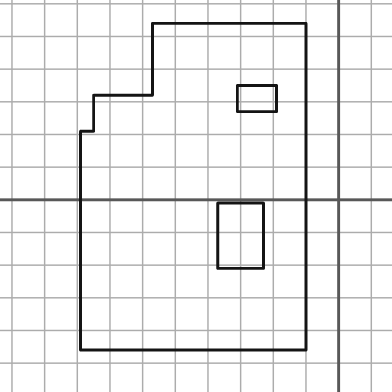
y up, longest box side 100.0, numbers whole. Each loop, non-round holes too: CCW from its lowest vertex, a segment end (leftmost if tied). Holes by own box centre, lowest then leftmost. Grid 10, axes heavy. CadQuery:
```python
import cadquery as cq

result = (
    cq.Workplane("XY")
    .moveTo(-79.0, -46.0)
    .lineTo(-10.0, -46.0)
    .lineTo(-10.0, 54.0)
    .lineTo(-57.0, 54.0)
    .lineTo(-57.0, 32.0)
    .lineTo(-75.0, 32.0)
    .lineTo(-75.0, 21.0)
    .lineTo(-79.0, 21.0)
    .close()
    .moveTo(-37.0, -21.0)
    .lineTo(-23.0, -21.0)
    .lineTo(-23.0, -1.0)
    .lineTo(-37.0, -1.0)
    .close()
    .moveTo(-31.0, 27.0)
    .lineTo(-19.0, 27.0)
    .lineTo(-19.0, 35.0)
    .lineTo(-31.0, 35.0)
    .close()
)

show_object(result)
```